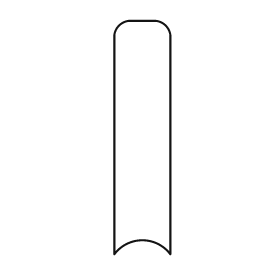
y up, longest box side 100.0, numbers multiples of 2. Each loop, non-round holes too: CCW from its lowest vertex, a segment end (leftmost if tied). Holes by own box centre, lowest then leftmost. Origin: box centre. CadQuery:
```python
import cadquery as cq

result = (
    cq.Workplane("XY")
    .moveTo(-12.0, -50.0)
    .threePointArc((0.0, -44.0), (12.0, -50.0))
    .lineTo(12.0, 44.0)
    .threePointArc((10.0, 48.0), (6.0, 50.0))
    .lineTo(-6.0, 50.0)
    .threePointArc((-10.0, 48.0), (-12.0, 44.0))
    .close()
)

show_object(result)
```